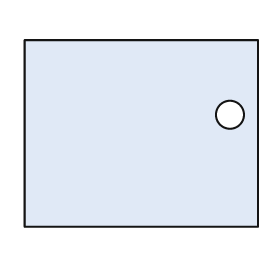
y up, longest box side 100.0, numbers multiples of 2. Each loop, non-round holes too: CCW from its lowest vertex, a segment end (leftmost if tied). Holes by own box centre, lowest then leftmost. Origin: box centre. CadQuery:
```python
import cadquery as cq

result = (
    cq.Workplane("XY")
    .moveTo(-50.0, -40.0)
    .lineTo(50.0, -40.0)
    .lineTo(50.0, 40.0)
    .lineTo(-50.0, 40.0)
    .close()
    .moveTo(38.0, 8.0)
    .circle(6.0)
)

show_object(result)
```